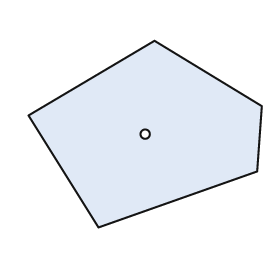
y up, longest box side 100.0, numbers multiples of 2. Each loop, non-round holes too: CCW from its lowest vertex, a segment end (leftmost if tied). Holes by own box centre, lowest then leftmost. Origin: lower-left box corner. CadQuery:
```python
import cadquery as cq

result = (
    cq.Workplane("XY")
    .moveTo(30.0, 0.0)
    .lineTo(98.0, 24.0)
    .lineTo(100.0, 52.0)
    .lineTo(54.0, 80.0)
    .lineTo(0.0, 48.0)
    .close()
    .moveTo(50.0, 40.0)
    .circle(2.0)
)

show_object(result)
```